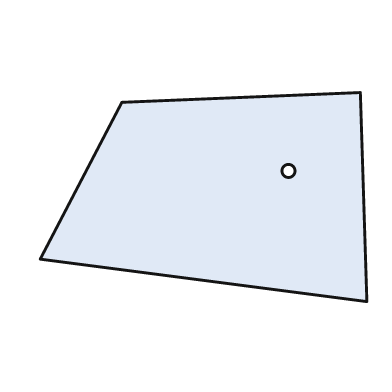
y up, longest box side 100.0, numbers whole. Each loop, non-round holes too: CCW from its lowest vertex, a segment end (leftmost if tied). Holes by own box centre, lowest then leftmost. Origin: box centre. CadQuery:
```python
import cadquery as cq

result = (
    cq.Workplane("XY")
    .moveTo(50.0, -32.0)
    .lineTo(48.0, 32.0)
    .lineTo(-25.0, 29.0)
    .lineTo(-50.0, -19.0)
    .close()
    .moveTo(26.0, 8.0)
    .circle(2.0)
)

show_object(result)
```